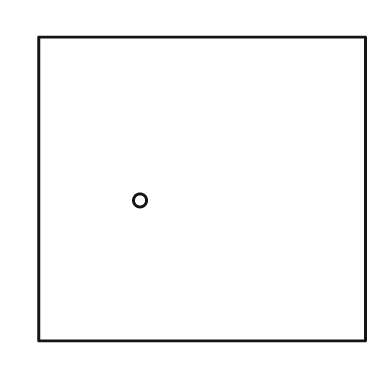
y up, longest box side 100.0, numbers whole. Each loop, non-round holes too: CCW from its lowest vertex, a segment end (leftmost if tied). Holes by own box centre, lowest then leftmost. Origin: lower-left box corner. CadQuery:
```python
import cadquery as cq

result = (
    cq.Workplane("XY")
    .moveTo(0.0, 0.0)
    .lineTo(100.0, 0.0)
    .lineTo(100.0, 93.0)
    .lineTo(0.0, 93.0)
    .close()
    .moveTo(31.0, 43.0)
    .circle(2.0)
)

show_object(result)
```